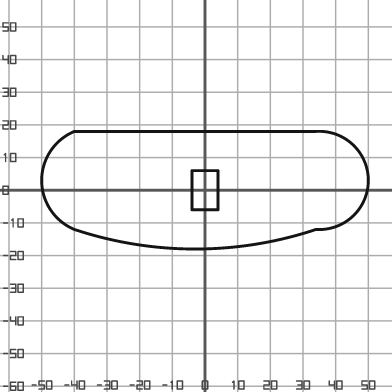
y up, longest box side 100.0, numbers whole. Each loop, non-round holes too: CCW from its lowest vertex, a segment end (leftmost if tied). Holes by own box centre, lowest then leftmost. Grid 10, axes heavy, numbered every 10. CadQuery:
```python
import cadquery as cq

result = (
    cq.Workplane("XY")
    .moveTo(-40.0, -12.0)
    .threePointArc((-3.0, -18.0), (34.0, -12.0))
    .threePointArc((50.0, 3.0), (34.0, 18.0))
    .lineTo(-40.0, 18.0)
    .threePointArc((-50.0, 3.0), (-40.0, -12.0))
    .close()
    .moveTo(-4.0, -6.0)
    .lineTo(4.0, -6.0)
    .lineTo(4.0, 6.0)
    .lineTo(-4.0, 6.0)
    .close()
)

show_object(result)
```